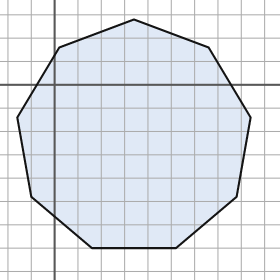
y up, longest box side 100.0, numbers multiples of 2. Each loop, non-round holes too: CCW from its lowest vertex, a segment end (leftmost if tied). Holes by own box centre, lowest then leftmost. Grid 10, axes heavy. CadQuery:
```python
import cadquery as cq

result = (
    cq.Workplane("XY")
    .moveTo(16.0, -70.0)
    .lineTo(52.0, -70.0)
    .lineTo(78.0, -48.0)
    .lineTo(84.0, -14.0)
    .lineTo(66.0, 16.0)
    .lineTo(34.0, 28.0)
    .lineTo(2.0, 16.0)
    .lineTo(-16.0, -14.0)
    .lineTo(-10.0, -48.0)
    .close()
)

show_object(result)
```